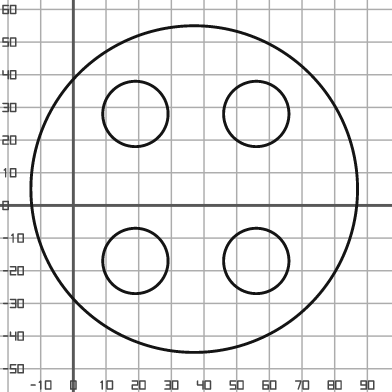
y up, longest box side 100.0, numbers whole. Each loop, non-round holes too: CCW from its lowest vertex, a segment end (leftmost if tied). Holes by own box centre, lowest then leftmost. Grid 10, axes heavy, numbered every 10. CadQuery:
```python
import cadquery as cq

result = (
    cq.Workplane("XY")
    .moveTo(37.0, 5.0)
    .circle(50.0)
    .moveTo(19.0, -17.0)
    .circle(10.0)
    .moveTo(56.0, -17.0)
    .circle(10.0)
    .moveTo(19.0, 28.0)
    .circle(10.0)
    .moveTo(56.0, 28.0)
    .circle(10.0)
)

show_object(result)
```